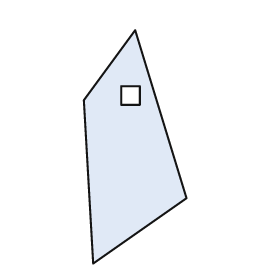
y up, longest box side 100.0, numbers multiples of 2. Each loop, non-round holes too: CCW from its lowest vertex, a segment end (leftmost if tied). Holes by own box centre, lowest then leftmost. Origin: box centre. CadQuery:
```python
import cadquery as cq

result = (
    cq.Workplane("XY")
    .moveTo(-18.0, -50.0)
    .lineTo(22.0, -22.0)
    .lineTo(0.0, 50.0)
    .lineTo(-22.0, 20.0)
    .close()
    .moveTo(-6.0, 18.0)
    .lineTo(2.0, 18.0)
    .lineTo(2.0, 26.0)
    .lineTo(-6.0, 26.0)
    .close()
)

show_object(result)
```